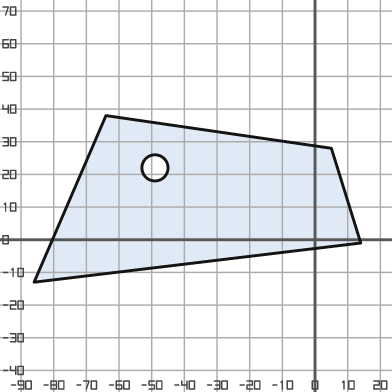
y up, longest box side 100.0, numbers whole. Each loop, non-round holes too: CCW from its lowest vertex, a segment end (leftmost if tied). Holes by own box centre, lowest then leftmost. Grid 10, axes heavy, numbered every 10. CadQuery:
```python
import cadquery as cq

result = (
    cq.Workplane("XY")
    .moveTo(-86.0, -13.0)
    .lineTo(14.0, -1.0)
    .lineTo(5.0, 28.0)
    .lineTo(-64.0, 38.0)
    .close()
    .moveTo(-49.0, 22.0)
    .circle(4.0)
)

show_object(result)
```